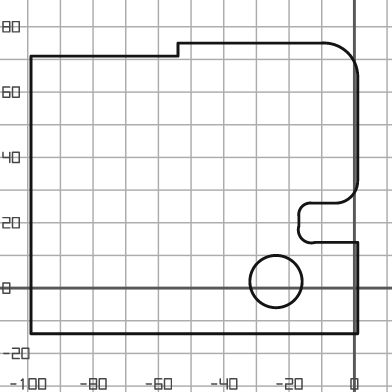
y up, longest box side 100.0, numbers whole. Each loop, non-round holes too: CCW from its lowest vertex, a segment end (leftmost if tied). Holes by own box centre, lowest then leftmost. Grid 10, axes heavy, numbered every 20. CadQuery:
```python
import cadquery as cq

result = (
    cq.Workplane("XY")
    .moveTo(-99.0, -14.0)
    .lineTo(1.0, -14.0)
    .lineTo(1.0, 14.0)
    .lineTo(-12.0, 14.0)
    .threePointArc((-16.0, 15.0), (-17.0, 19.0))
    .lineTo(-17.0, 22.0)
    .threePointArc((-16.0, 25.0), (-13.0, 26.0))
    .lineTo(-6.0, 26.0)
    .threePointArc((-1.0, 28.0), (1.0, 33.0))
    .lineTo(1.0, 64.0)
    .threePointArc((-2.0, 72.0), (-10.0, 75.0))
    .lineTo(-54.0, 75.0)
    .lineTo(-54.0, 71.0)
    .lineTo(-99.0, 71.0)
    .close()
    .moveTo(-24.0, 2.0)
    .circle(8.0)
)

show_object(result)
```